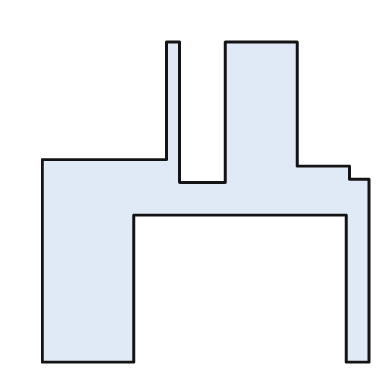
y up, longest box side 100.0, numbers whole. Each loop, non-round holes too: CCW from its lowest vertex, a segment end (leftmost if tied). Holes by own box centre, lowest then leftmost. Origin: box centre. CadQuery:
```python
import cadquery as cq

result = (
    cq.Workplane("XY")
    .moveTo(-50.0, -49.0)
    .lineTo(-22.0, -49.0)
    .lineTo(-22.0, -4.0)
    .lineTo(43.0, -4.0)
    .lineTo(43.0, -49.0)
    .lineTo(50.0, -49.0)
    .lineTo(50.0, 7.0)
    .lineTo(44.0, 7.0)
    .lineTo(44.0, 11.0)
    .lineTo(28.0, 11.0)
    .lineTo(28.0, 49.0)
    .lineTo(6.0, 49.0)
    .lineTo(6.0, 6.0)
    .lineTo(-8.0, 6.0)
    .lineTo(-8.0, 49.0)
    .lineTo(-12.0, 49.0)
    .lineTo(-12.0, 13.0)
    .lineTo(-50.0, 13.0)
    .close()
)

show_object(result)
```